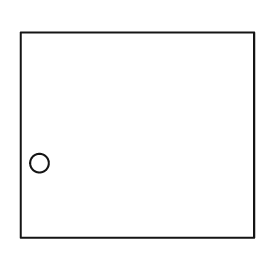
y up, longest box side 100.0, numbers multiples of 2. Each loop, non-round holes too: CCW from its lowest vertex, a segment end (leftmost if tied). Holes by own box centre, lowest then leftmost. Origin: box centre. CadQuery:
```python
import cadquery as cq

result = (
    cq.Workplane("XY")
    .moveTo(-50.0, -44.0)
    .lineTo(50.0, -44.0)
    .lineTo(50.0, 44.0)
    .lineTo(-50.0, 44.0)
    .close()
    .moveTo(-42.0, -12.0)
    .circle(4.0)
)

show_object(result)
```